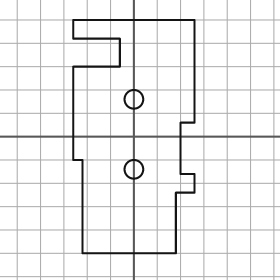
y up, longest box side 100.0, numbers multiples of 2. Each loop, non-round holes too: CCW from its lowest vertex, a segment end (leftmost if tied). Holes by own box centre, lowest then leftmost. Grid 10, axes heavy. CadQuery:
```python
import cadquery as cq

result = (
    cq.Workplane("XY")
    .moveTo(-22.0, -50.0)
    .lineTo(18.0, -50.0)
    .lineTo(18.0, -24.0)
    .lineTo(26.0, -24.0)
    .lineTo(26.0, -16.0)
    .lineTo(20.0, -16.0)
    .lineTo(20.0, 6.0)
    .lineTo(26.0, 6.0)
    .lineTo(26.0, 50.0)
    .lineTo(-26.0, 50.0)
    .lineTo(-26.0, 42.0)
    .lineTo(-6.0, 42.0)
    .lineTo(-6.0, 30.0)
    .lineTo(-26.0, 30.0)
    .lineTo(-26.0, -10.0)
    .lineTo(-22.0, -10.0)
    .close()
    .moveTo(0.0, -14.0)
    .circle(4.0)
    .moveTo(0.0, 16.0)
    .circle(4.0)
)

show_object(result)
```